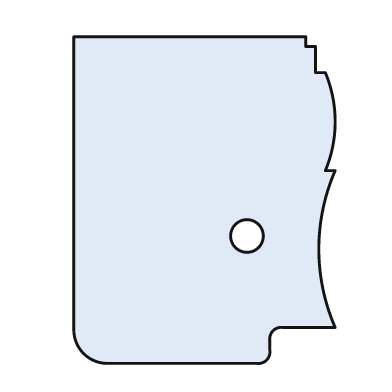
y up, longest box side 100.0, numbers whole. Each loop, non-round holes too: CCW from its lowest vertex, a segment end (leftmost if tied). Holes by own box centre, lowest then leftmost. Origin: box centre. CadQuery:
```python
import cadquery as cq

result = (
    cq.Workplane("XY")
    .moveTo(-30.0, -50.0)
    .lineTo(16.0, -50.0)
    .threePointArc((19.0, -49.0), (20.0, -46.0))
    .lineTo(20.0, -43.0)
    .threePointArc((21.0, -40.0), (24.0, -39.0))
    .lineTo(40.0, -39.0)
    .threePointArc((35.0, -15.0), (40.0, 9.0))
    .lineTo(37.0, 9.0)
    .threePointArc((40.0, 24.0), (37.0, 39.0))
    .lineTo(34.0, 39.0)
    .lineTo(34.0, 47.0)
    .lineTo(31.0, 47.0)
    .lineTo(31.0, 50.0)
    .lineTo(-40.0, 50.0)
    .lineTo(-40.0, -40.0)
    .threePointArc((-37.0, -47.0), (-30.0, -50.0))
    .close()
    .moveTo(13.0, -11.0)
    .circle(5.0)
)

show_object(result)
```